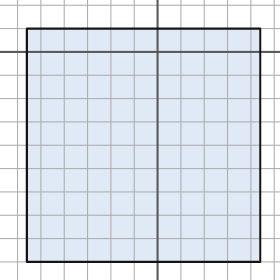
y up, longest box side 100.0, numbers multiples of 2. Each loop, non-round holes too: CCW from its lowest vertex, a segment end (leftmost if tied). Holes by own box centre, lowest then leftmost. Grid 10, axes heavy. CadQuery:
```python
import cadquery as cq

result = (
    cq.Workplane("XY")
    .moveTo(-56.0, -90.0)
    .lineTo(44.0, -90.0)
    .lineTo(44.0, 10.0)
    .lineTo(-56.0, 10.0)
    .close()
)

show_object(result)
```